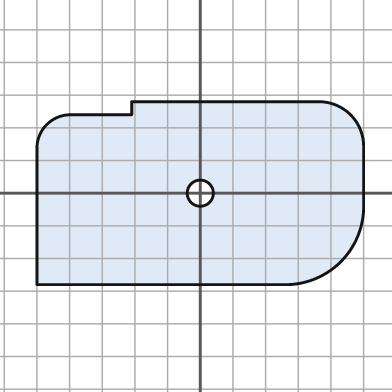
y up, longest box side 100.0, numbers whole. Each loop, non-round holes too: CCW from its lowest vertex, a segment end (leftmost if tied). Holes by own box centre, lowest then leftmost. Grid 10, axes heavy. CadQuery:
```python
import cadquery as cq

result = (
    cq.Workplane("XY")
    .moveTo(-50.0, -28.0)
    .lineTo(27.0, -28.0)
    .threePointArc((43.0, -21.0), (50.0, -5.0))
    .lineTo(50.0, 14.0)
    .threePointArc((46.0, 24.0), (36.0, 28.0))
    .lineTo(-21.0, 28.0)
    .lineTo(-21.0, 24.0)
    .lineTo(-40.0, 24.0)
    .threePointArc((-47.0, 21.0), (-50.0, 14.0))
    .close()
    .moveTo(0.0, 0.0)
    .circle(4.0)
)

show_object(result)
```